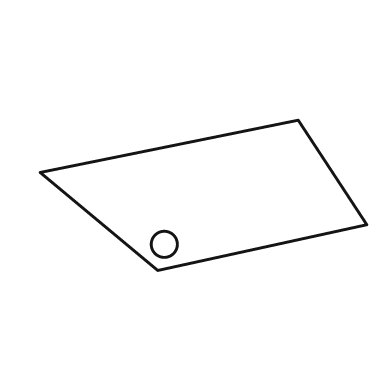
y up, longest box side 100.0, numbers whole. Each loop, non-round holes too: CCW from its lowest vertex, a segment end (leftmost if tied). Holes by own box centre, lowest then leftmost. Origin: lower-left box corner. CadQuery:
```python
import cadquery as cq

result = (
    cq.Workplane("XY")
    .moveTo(36.0, 0.0)
    .lineTo(100.0, 14.0)
    .lineTo(79.0, 46.0)
    .lineTo(0.0, 30.0)
    .close()
    .moveTo(38.0, 8.0)
    .circle(4.0)
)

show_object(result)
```